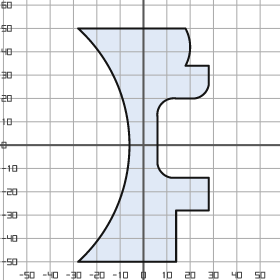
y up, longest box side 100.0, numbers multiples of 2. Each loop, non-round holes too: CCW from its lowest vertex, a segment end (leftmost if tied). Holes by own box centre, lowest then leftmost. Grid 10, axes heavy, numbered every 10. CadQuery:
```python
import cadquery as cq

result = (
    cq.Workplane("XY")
    .moveTo(-28.0, -50.0)
    .lineTo(14.0, -50.0)
    .lineTo(14.0, -28.0)
    .lineTo(28.0, -28.0)
    .lineTo(28.0, -14.0)
    .lineTo(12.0, -14.0)
    .threePointArc((8.0, -12.0), (6.0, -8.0))
    .lineTo(6.0, 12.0)
    .threePointArc((8.0, 18.0), (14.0, 20.0))
    .lineTo(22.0, 20.0)
    .threePointArc((26.0, 22.0), (28.0, 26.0))
    .lineTo(28.0, 34.0)
    .lineTo(18.0, 34.0)
    .threePointArc((20.0, 42.0), (18.0, 50.0))
    .lineTo(-28.0, 50.0)
    .threePointArc((-6.0, 0.0), (-28.0, -50.0))
    .close()
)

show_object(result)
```